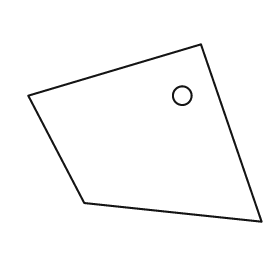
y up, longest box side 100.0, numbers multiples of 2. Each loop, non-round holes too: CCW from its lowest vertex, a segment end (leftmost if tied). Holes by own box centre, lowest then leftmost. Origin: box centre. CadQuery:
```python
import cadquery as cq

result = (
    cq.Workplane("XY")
    .moveTo(50.0, -38.0)
    .lineTo(24.0, 38.0)
    .lineTo(-50.0, 16.0)
    .lineTo(-26.0, -30.0)
    .close()
    .moveTo(16.0, 16.0)
    .circle(4.0)
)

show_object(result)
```